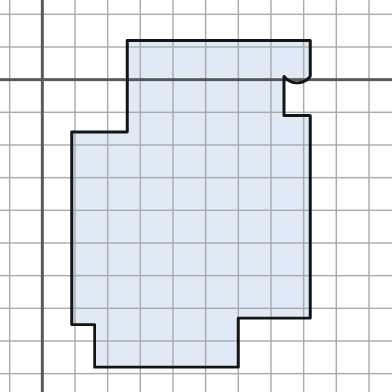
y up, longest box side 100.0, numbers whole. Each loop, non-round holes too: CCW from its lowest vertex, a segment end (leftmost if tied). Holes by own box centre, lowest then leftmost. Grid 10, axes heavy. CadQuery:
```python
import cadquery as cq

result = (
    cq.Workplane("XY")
    .moveTo(16.0, -88.0)
    .lineTo(60.0, -88.0)
    .lineTo(60.0, -73.0)
    .lineTo(82.0, -73.0)
    .lineTo(82.0, -11.0)
    .lineTo(74.0, -11.0)
    .lineTo(74.0, 1.0)
    .threePointArc((78.0, -1.0), (82.0, 1.0))
    .lineTo(82.0, 12.0)
    .lineTo(26.0, 12.0)
    .lineTo(26.0, -16.0)
    .lineTo(9.0, -16.0)
    .lineTo(9.0, -75.0)
    .lineTo(16.0, -75.0)
    .close()
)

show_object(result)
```